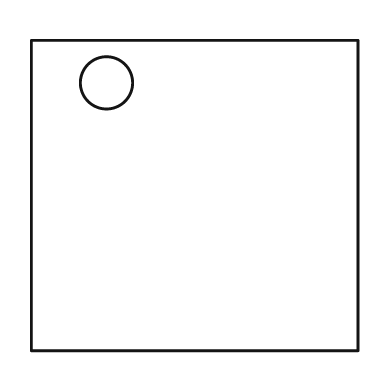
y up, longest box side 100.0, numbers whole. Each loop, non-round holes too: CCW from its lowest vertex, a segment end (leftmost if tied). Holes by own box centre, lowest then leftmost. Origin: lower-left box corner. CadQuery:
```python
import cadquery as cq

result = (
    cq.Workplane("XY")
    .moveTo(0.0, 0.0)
    .lineTo(100.0, 0.0)
    .lineTo(100.0, 95.0)
    .lineTo(0.0, 95.0)
    .close()
    .moveTo(23.0, 82.0)
    .circle(8.0)
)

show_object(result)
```